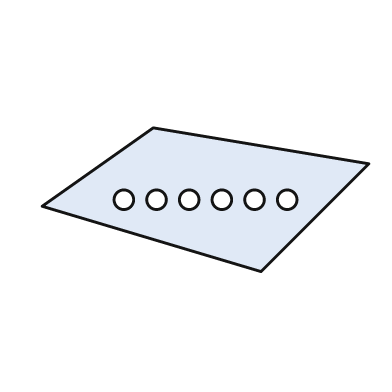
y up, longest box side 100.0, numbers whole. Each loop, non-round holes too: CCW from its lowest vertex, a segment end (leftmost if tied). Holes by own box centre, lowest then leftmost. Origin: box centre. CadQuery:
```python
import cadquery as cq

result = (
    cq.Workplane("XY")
    .moveTo(17.0, -22.0)
    .lineTo(50.0, 11.0)
    .lineTo(-16.0, 22.0)
    .lineTo(-50.0, -2.0)
    .close()
    .moveTo(-25.0, 0.0)
    .circle(3.0)
    .moveTo(-15.0, 0.0)
    .circle(3.0)
    .moveTo(-5.0, 0.0)
    .circle(3.0)
    .moveTo(5.0, 0.0)
    .circle(3.0)
    .moveTo(15.0, 0.0)
    .circle(3.0)
    .moveTo(25.0, 0.0)
    .circle(3.0)
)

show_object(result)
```